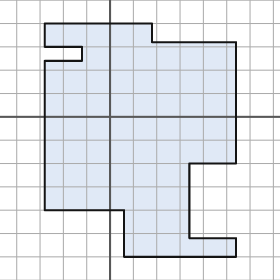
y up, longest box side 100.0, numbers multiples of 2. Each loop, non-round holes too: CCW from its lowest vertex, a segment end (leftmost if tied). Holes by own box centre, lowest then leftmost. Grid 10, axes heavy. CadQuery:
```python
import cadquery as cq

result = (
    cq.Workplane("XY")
    .moveTo(6.0, -60.0)
    .lineTo(54.0, -60.0)
    .lineTo(54.0, -52.0)
    .lineTo(34.0, -52.0)
    .lineTo(34.0, -20.0)
    .lineTo(54.0, -20.0)
    .lineTo(54.0, 32.0)
    .lineTo(18.0, 32.0)
    .lineTo(18.0, 40.0)
    .lineTo(-28.0, 40.0)
    .lineTo(-28.0, 30.0)
    .lineTo(-12.0, 30.0)
    .lineTo(-12.0, 24.0)
    .lineTo(-28.0, 24.0)
    .lineTo(-28.0, -40.0)
    .lineTo(6.0, -40.0)
    .close()
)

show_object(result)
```